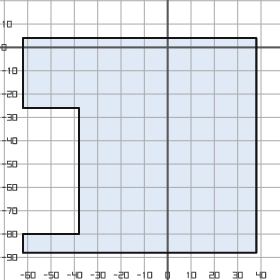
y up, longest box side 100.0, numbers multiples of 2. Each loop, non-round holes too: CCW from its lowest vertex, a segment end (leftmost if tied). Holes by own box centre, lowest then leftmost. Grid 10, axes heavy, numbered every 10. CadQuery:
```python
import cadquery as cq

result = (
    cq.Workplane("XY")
    .moveTo(-62.0, -88.0)
    .lineTo(38.0, -88.0)
    .lineTo(38.0, 4.0)
    .lineTo(-62.0, 4.0)
    .lineTo(-62.0, -26.0)
    .lineTo(-38.0, -26.0)
    .lineTo(-38.0, -80.0)
    .lineTo(-62.0, -80.0)
    .close()
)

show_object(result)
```